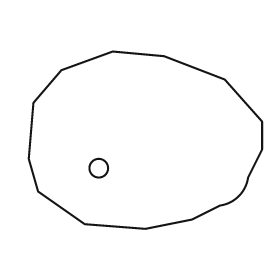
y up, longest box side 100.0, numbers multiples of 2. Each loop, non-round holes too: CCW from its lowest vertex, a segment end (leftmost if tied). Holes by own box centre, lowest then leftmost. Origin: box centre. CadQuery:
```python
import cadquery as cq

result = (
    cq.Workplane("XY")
    .moveTo(0.0, -38.0)
    .lineTo(20.0, -34.0)
    .lineTo(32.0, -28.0)
    .threePointArc((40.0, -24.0), (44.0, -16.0))
    .lineTo(50.0, -4.0)
    .lineTo(50.0, 8.0)
    .lineTo(34.0, 26.0)
    .lineTo(8.0, 36.0)
    .lineTo(-14.0, 38.0)
    .lineTo(-36.0, 30.0)
    .lineTo(-48.0, 16.0)
    .lineTo(-50.0, -8.0)
    .lineTo(-46.0, -22.0)
    .lineTo(-26.0, -36.0)
    .close()
    .moveTo(-20.0, -12.0)
    .circle(4.0)
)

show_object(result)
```